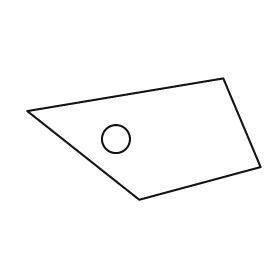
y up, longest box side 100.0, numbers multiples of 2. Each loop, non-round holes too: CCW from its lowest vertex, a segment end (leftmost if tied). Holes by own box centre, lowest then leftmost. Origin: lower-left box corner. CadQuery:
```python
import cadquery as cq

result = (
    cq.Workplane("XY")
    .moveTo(48.0, 0.0)
    .lineTo(100.0, 14.0)
    .lineTo(84.0, 52.0)
    .lineTo(0.0, 38.0)
    .close()
    .moveTo(38.0, 26.0)
    .circle(6.0)
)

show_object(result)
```